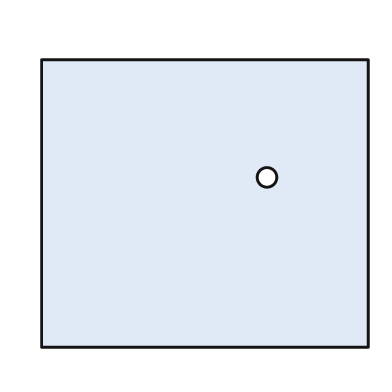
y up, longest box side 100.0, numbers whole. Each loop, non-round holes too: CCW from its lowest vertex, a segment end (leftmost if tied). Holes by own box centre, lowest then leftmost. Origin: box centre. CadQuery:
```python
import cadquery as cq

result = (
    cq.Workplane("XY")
    .moveTo(-50.0, -44.0)
    .lineTo(50.0, -44.0)
    .lineTo(50.0, 44.0)
    .lineTo(-50.0, 44.0)
    .close()
    .moveTo(19.0, 8.0)
    .circle(3.0)
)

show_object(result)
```